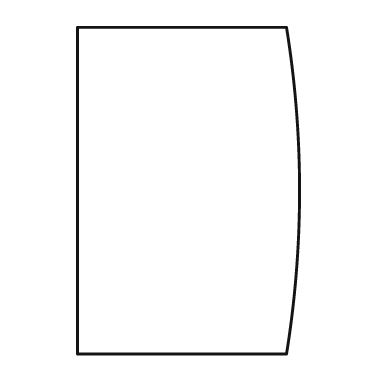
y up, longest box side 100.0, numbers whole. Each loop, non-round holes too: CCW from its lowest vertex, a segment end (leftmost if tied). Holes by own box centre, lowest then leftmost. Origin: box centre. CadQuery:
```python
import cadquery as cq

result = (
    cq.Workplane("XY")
    .moveTo(-34.0, -50.0)
    .lineTo(30.0, -50.0)
    .threePointArc((34.0, 0.0), (30.0, 50.0))
    .lineTo(-34.0, 50.0)
    .close()
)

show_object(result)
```